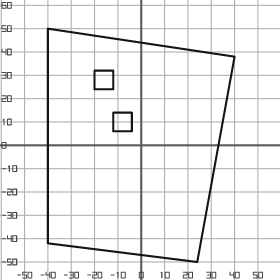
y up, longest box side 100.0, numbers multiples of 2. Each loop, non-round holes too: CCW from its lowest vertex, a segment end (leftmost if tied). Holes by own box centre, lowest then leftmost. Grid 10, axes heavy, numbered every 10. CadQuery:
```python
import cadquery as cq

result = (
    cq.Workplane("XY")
    .moveTo(24.0, -50.0)
    .lineTo(40.0, 38.0)
    .lineTo(-40.0, 50.0)
    .lineTo(-40.0, -42.0)
    .close()
    .moveTo(-12.0, 6.0)
    .lineTo(-4.0, 6.0)
    .lineTo(-4.0, 14.0)
    .lineTo(-12.0, 14.0)
    .close()
    .moveTo(-20.0, 24.0)
    .lineTo(-12.0, 24.0)
    .lineTo(-12.0, 32.0)
    .lineTo(-20.0, 32.0)
    .close()
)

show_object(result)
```